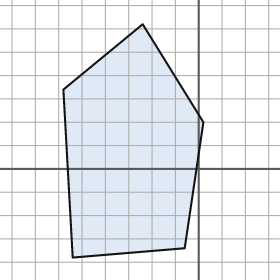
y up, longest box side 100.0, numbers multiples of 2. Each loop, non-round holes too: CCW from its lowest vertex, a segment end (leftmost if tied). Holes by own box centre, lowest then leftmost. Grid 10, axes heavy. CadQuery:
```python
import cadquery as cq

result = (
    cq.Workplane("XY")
    .moveTo(-54.0, -38.0)
    .lineTo(-6.0, -34.0)
    .lineTo(2.0, 20.0)
    .lineTo(-24.0, 62.0)
    .lineTo(-58.0, 34.0)
    .close()
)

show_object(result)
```